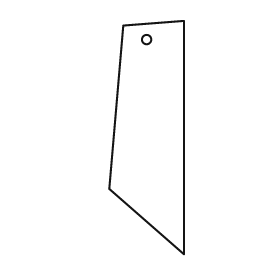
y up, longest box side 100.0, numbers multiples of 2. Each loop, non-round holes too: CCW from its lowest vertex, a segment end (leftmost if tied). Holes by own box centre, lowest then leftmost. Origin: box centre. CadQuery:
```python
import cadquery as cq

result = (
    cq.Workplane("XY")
    .moveTo(16.0, -50.0)
    .lineTo(16.0, 50.0)
    .lineTo(-10.0, 48.0)
    .lineTo(-16.0, -22.0)
    .close()
    .moveTo(0.0, 42.0)
    .circle(2.0)
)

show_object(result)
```